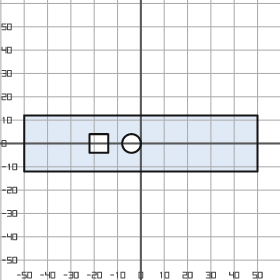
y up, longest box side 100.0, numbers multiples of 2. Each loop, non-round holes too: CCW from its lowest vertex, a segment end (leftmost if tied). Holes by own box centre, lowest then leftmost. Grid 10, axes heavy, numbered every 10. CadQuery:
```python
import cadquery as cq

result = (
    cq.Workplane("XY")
    .moveTo(-50.0, -12.0)
    .lineTo(50.0, -12.0)
    .lineTo(50.0, 12.0)
    .lineTo(-50.0, 12.0)
    .close()
    .moveTo(-22.0, -4.0)
    .lineTo(-14.0, -4.0)
    .lineTo(-14.0, 4.0)
    .lineTo(-22.0, 4.0)
    .close()
    .moveTo(-4.0, 0.0)
    .circle(4.0)
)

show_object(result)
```